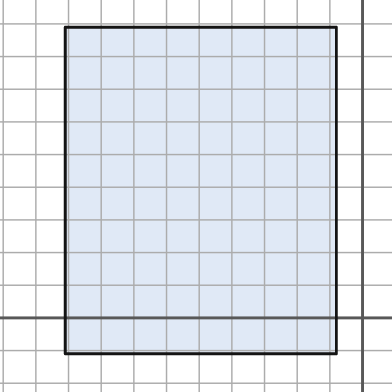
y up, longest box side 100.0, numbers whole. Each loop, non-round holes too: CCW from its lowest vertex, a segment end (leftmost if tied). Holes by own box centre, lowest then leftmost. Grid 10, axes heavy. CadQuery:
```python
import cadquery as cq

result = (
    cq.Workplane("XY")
    .moveTo(-91.0, -11.0)
    .lineTo(-8.0, -11.0)
    .lineTo(-8.0, 89.0)
    .lineTo(-91.0, 89.0)
    .close()
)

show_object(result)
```